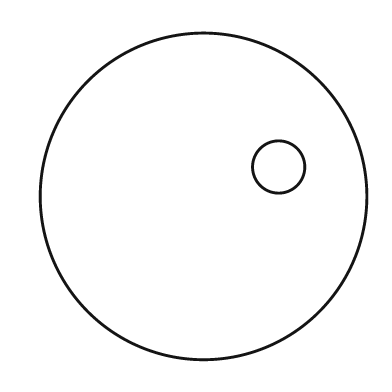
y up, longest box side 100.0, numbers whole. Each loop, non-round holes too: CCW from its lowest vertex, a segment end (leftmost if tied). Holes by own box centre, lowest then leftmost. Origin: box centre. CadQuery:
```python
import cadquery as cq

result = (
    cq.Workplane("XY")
    .moveTo(0.0, 0.0)
    .circle(50.0)
    .moveTo(23.0, 9.0)
    .circle(8.0)
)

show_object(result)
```